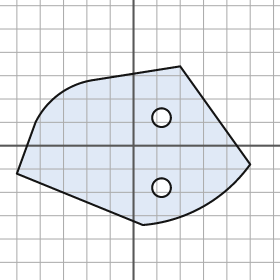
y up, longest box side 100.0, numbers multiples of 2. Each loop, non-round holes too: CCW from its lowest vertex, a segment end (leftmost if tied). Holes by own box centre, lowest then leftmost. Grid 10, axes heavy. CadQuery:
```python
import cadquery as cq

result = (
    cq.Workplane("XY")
    .moveTo(4.0, -34.0)
    .threePointArc((30.0, -26.0), (50.0, -8.0))
    .lineTo(20.0, 34.0)
    .lineTo(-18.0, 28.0)
    .threePointArc((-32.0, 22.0), (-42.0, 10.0))
    .lineTo(-50.0, -12.0)
    .close()
    .moveTo(12.0, -18.0)
    .circle(4.0)
    .moveTo(12.0, 12.0)
    .circle(4.0)
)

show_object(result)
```